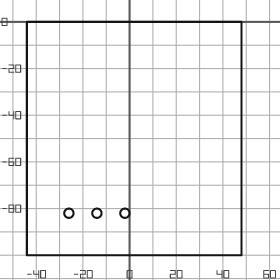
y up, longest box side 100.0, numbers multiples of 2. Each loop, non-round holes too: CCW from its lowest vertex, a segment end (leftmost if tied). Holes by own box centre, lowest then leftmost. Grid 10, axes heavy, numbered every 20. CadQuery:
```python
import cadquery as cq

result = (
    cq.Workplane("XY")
    .moveTo(-44.0, -100.0)
    .lineTo(48.0, -100.0)
    .lineTo(48.0, 0.0)
    .lineTo(-44.0, 0.0)
    .close()
    .moveTo(-26.0, -82.0)
    .circle(2.0)
    .moveTo(-14.0, -82.0)
    .circle(2.0)
    .moveTo(-2.0, -82.0)
    .circle(2.0)
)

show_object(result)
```